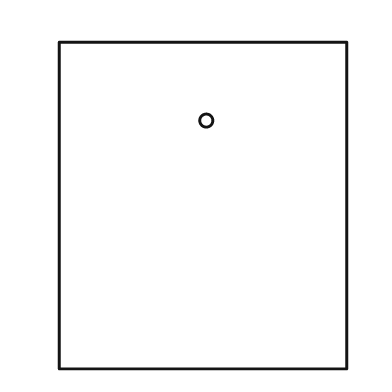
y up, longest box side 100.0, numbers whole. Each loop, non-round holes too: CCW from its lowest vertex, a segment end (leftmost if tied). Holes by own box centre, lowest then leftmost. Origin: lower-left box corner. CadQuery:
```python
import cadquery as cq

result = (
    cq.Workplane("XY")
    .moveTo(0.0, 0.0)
    .lineTo(88.0, 0.0)
    .lineTo(88.0, 100.0)
    .lineTo(0.0, 100.0)
    .close()
    .moveTo(45.0, 76.0)
    .circle(2.0)
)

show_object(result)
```